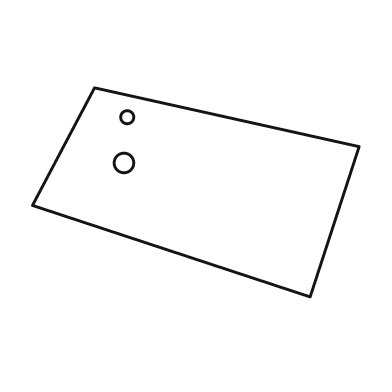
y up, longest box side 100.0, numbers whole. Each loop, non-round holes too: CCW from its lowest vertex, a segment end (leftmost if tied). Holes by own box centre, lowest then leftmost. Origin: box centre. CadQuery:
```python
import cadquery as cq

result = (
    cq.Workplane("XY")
    .moveTo(35.0, -32.0)
    .lineTo(50.0, 14.0)
    .lineTo(-31.0, 32.0)
    .lineTo(-50.0, -4.0)
    .close()
    .moveTo(-22.0, 9.0)
    .circle(3.0)
    .moveTo(-21.0, 23.0)
    .circle(2.0)
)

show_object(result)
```